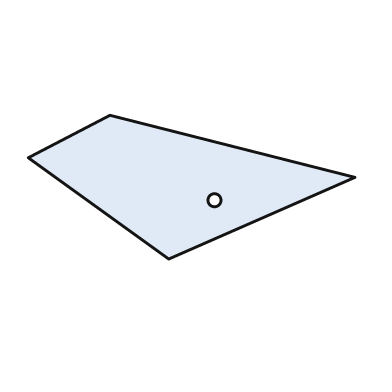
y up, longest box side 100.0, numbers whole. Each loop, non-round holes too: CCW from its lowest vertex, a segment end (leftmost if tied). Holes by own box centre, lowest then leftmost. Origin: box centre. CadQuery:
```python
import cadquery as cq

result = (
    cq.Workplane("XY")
    .moveTo(-7.0, -22.0)
    .lineTo(50.0, 3.0)
    .lineTo(-25.0, 22.0)
    .lineTo(-50.0, 9.0)
    .close()
    .moveTo(7.0, -4.0)
    .circle(2.0)
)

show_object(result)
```